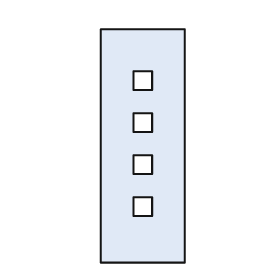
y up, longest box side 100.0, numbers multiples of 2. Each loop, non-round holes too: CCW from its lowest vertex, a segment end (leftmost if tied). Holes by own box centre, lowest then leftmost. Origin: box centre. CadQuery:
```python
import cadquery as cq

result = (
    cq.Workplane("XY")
    .moveTo(-18.0, -50.0)
    .lineTo(18.0, -50.0)
    .lineTo(18.0, 50.0)
    .lineTo(-18.0, 50.0)
    .close()
    .moveTo(-4.0, -30.0)
    .lineTo(4.0, -30.0)
    .lineTo(4.0, -22.0)
    .lineTo(-4.0, -22.0)
    .close()
    .moveTo(-4.0, -12.0)
    .lineTo(4.0, -12.0)
    .lineTo(4.0, -4.0)
    .lineTo(-4.0, -4.0)
    .close()
    .moveTo(-4.0, 6.0)
    .lineTo(4.0, 6.0)
    .lineTo(4.0, 14.0)
    .lineTo(-4.0, 14.0)
    .close()
    .moveTo(-4.0, 24.0)
    .lineTo(4.0, 24.0)
    .lineTo(4.0, 32.0)
    .lineTo(-4.0, 32.0)
    .close()
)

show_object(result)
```